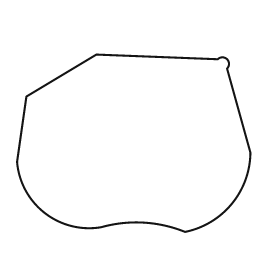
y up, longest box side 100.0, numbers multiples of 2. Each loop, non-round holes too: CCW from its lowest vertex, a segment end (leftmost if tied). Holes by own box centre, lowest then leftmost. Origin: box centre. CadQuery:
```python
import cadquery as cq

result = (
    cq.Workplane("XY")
    .moveTo(22.0, -38.0)
    .threePointArc((42.0, -26.0), (50.0, -4.0))
    .lineTo(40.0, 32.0)
    .threePointArc((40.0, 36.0), (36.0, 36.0))
    .lineTo(-16.0, 38.0)
    .lineTo(-46.0, 20.0)
    .lineTo(-50.0, -8.0)
    .threePointArc((-38.0, -30.0), (-14.0, -36.0))
    .threePointArc((4.0, -34.0), (22.0, -38.0))
    .close()
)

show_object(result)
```